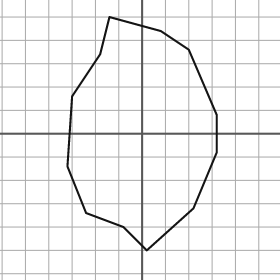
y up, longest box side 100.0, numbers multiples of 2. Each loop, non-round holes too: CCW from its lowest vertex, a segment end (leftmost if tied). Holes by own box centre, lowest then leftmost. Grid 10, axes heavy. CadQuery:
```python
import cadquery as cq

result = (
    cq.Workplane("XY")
    .moveTo(2.0, -50.0)
    .lineTo(22.0, -32.0)
    .lineTo(32.0, -8.0)
    .lineTo(32.0, 8.0)
    .lineTo(20.0, 36.0)
    .lineTo(8.0, 44.0)
    .lineTo(-14.0, 50.0)
    .lineTo(-18.0, 34.0)
    .lineTo(-30.0, 16.0)
    .lineTo(-32.0, -14.0)
    .lineTo(-24.0, -34.0)
    .lineTo(-8.0, -40.0)
    .close()
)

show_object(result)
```